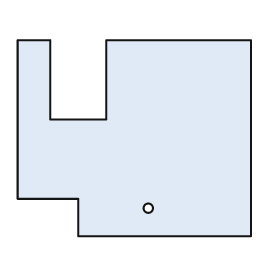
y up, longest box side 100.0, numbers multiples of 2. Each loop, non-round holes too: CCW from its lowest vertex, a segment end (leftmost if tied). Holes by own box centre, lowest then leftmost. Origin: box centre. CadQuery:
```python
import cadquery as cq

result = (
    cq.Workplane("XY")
    .moveTo(-24.0, -42.0)
    .lineTo(50.0, -42.0)
    .lineTo(50.0, 42.0)
    .lineTo(-12.0, 42.0)
    .lineTo(-12.0, 8.0)
    .lineTo(-36.0, 8.0)
    .lineTo(-36.0, 42.0)
    .lineTo(-50.0, 42.0)
    .lineTo(-50.0, -26.0)
    .lineTo(-24.0, -26.0)
    .close()
    .moveTo(6.0, -30.0)
    .circle(2.0)
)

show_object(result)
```